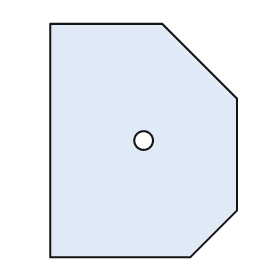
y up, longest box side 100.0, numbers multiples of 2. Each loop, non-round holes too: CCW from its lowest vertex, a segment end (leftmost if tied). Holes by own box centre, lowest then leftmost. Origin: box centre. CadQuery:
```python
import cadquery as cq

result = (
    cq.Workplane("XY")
    .moveTo(-40.0, -50.0)
    .lineTo(20.0, -50.0)
    .lineTo(40.0, -30.0)
    .lineTo(40.0, 18.0)
    .lineTo(8.0, 50.0)
    .lineTo(-40.0, 50.0)
    .close()
    .moveTo(0.0, 0.0)
    .circle(4.0)
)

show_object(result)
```